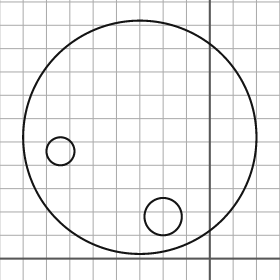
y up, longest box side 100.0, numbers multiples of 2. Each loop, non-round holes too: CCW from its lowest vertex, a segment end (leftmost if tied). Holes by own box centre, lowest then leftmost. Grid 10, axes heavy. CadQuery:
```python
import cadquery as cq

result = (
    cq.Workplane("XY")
    .moveTo(-30.0, 52.0)
    .circle(50.0)
    .moveTo(-20.0, 18.0)
    .circle(8.0)
    .moveTo(-64.0, 46.0)
    .circle(6.0)
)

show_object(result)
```